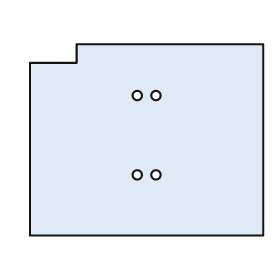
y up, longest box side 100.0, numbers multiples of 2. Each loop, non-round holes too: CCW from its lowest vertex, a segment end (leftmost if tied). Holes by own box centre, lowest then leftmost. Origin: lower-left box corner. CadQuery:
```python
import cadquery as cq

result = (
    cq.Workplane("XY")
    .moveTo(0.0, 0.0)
    .lineTo(100.0, 0.0)
    .lineTo(100.0, 82.0)
    .lineTo(20.0, 82.0)
    .lineTo(20.0, 74.0)
    .lineTo(0.0, 74.0)
    .close()
    .moveTo(46.0, 26.0)
    .circle(2.0)
    .moveTo(54.0, 26.0)
    .circle(2.0)
    .moveTo(46.0, 60.0)
    .circle(2.0)
    .moveTo(54.0, 60.0)
    .circle(2.0)
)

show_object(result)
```